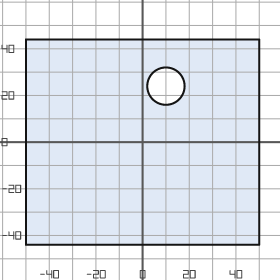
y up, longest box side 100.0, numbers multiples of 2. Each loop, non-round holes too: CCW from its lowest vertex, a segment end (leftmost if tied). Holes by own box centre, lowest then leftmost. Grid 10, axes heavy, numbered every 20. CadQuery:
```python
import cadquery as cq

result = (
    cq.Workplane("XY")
    .moveTo(-50.0, -44.0)
    .lineTo(50.0, -44.0)
    .lineTo(50.0, 44.0)
    .lineTo(-50.0, 44.0)
    .close()
    .moveTo(10.0, 24.0)
    .circle(8.0)
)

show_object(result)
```